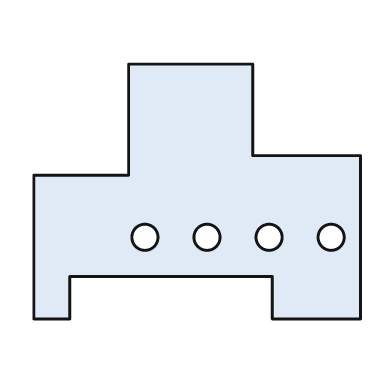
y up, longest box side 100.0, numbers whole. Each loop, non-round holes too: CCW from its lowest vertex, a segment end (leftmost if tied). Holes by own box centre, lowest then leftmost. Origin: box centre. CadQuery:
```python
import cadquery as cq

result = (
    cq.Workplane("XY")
    .moveTo(-50.0, -39.0)
    .lineTo(-39.0, -39.0)
    .lineTo(-39.0, -26.0)
    .lineTo(23.0, -26.0)
    .lineTo(23.0, -39.0)
    .lineTo(50.0, -39.0)
    .lineTo(50.0, 11.0)
    .lineTo(17.0, 11.0)
    .lineTo(17.0, 39.0)
    .lineTo(-21.0, 39.0)
    .lineTo(-21.0, 5.0)
    .lineTo(-50.0, 5.0)
    .close()
    .moveTo(-16.0, -14.0)
    .circle(4.0)
    .moveTo(3.0, -14.0)
    .circle(4.0)
    .moveTo(22.0, -14.0)
    .circle(4.0)
    .moveTo(41.0, -14.0)
    .circle(4.0)
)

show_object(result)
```